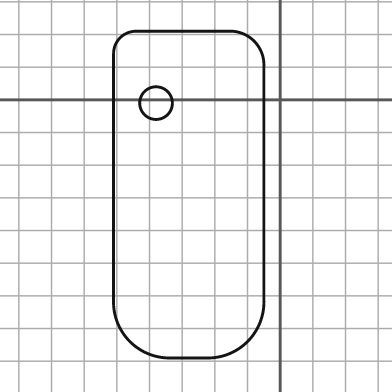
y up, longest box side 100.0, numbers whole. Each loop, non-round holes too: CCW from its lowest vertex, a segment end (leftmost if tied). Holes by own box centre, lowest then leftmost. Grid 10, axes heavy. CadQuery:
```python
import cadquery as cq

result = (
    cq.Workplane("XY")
    .moveTo(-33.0, -79.0)
    .lineTo(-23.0, -79.0)
    .threePointArc((-10.0, -74.0), (-5.0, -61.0))
    .lineTo(-5.0, 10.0)
    .threePointArc((-8.0, 18.0), (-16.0, 21.0))
    .lineTo(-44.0, 21.0)
    .threePointArc((-49.0, 19.0), (-51.0, 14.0))
    .lineTo(-51.0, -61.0)
    .threePointArc((-46.0, -74.0), (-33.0, -79.0))
    .close()
    .moveTo(-38.0, -1.0)
    .circle(5.0)
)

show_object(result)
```